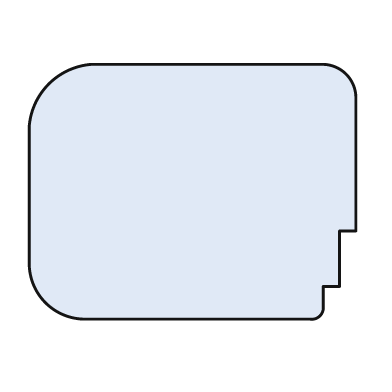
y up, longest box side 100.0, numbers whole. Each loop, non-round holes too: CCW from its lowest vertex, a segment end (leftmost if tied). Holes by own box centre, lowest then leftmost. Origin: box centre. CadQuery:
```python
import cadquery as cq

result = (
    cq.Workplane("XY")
    .moveTo(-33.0, -39.0)
    .lineTo(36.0, -39.0)
    .threePointArc((39.0, -38.0), (40.0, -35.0))
    .lineTo(40.0, -29.0)
    .lineTo(45.0, -29.0)
    .lineTo(45.0, -12.0)
    .lineTo(50.0, -12.0)
    .lineTo(50.0, 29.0)
    .threePointArc((47.0, 36.0), (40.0, 39.0))
    .lineTo(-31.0, 39.0)
    .threePointArc((-44.0, 33.0), (-50.0, 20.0))
    .lineTo(-50.0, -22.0)
    .threePointArc((-45.0, -34.0), (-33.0, -39.0))
    .close()
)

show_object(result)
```